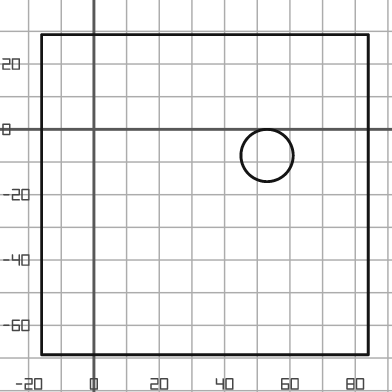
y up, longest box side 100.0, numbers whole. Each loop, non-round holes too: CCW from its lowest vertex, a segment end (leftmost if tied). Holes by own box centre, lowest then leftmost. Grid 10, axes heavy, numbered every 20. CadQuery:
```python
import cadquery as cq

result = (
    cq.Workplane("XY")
    .moveTo(-16.0, -69.0)
    .lineTo(84.0, -69.0)
    .lineTo(84.0, 29.0)
    .lineTo(-16.0, 29.0)
    .close()
    .moveTo(53.0, -8.0)
    .circle(8.0)
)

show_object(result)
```